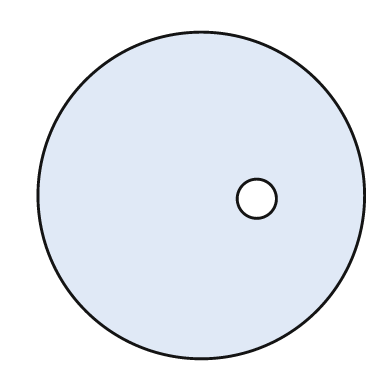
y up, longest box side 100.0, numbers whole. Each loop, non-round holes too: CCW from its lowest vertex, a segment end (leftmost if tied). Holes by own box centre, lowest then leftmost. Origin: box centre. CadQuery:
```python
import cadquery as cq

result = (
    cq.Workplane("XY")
    .moveTo(0.0, 0.0)
    .circle(50.0)
    .moveTo(17.0, -1.0)
    .circle(6.0)
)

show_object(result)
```